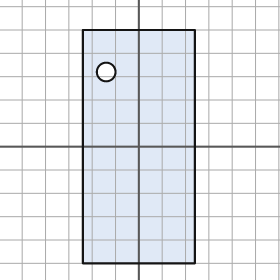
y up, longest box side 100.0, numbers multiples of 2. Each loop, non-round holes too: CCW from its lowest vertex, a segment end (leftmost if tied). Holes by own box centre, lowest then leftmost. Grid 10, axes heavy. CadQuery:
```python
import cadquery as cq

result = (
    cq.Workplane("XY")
    .moveTo(-24.0, -50.0)
    .lineTo(24.0, -50.0)
    .lineTo(24.0, 50.0)
    .lineTo(-24.0, 50.0)
    .close()
    .moveTo(-14.0, 32.0)
    .circle(4.0)
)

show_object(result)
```